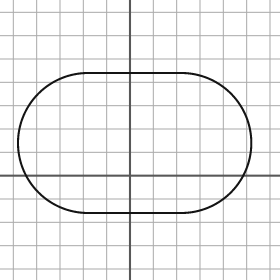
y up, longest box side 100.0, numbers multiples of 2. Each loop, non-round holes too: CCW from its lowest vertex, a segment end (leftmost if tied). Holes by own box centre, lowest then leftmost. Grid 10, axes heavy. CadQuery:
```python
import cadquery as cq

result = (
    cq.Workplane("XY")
    .moveTo(-18.0, -16.0)
    .lineTo(22.0, -16.0)
    .threePointArc((52.0, 14.0), (22.0, 44.0))
    .lineTo(-18.0, 44.0)
    .threePointArc((-48.0, 14.0), (-18.0, -16.0))
    .close()
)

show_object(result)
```